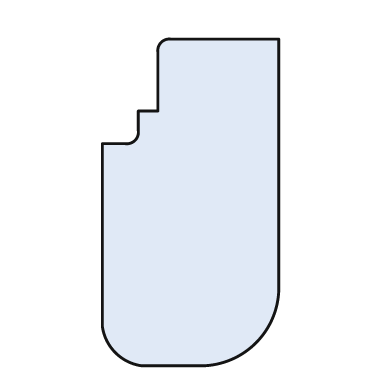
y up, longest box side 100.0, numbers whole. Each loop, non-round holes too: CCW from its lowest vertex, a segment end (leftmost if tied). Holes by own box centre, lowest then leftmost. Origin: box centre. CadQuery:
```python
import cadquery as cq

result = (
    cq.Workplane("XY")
    .moveTo(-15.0, -50.0)
    .lineTo(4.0, -50.0)
    .threePointArc((20.0, -43.0), (27.0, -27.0))
    .lineTo(27.0, 50.0)
    .lineTo(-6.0, 50.0)
    .threePointArc((-9.0, 49.0), (-10.0, 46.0))
    .lineTo(-10.0, 28.0)
    .lineTo(-16.0, 28.0)
    .lineTo(-16.0, 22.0)
    .threePointArc((-17.0, 19.0), (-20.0, 18.0))
    .lineTo(-27.0, 18.0)
    .lineTo(-27.0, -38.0)
    .threePointArc((-23.0, -46.0), (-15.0, -50.0))
    .close()
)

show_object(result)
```